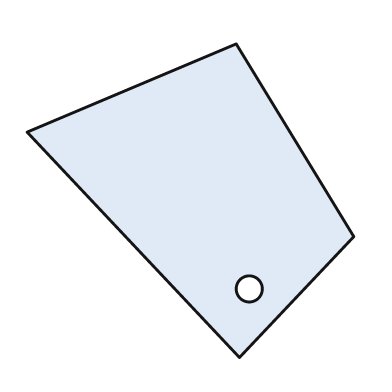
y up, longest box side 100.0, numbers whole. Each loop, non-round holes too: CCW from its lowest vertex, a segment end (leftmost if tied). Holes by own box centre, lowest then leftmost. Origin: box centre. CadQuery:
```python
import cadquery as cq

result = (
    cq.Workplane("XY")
    .moveTo(15.0, -48.0)
    .lineTo(50.0, -11.0)
    .lineTo(14.0, 48.0)
    .lineTo(-50.0, 21.0)
    .close()
    .moveTo(18.0, -27.0)
    .circle(4.0)
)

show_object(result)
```